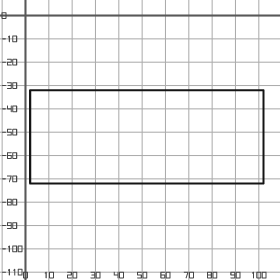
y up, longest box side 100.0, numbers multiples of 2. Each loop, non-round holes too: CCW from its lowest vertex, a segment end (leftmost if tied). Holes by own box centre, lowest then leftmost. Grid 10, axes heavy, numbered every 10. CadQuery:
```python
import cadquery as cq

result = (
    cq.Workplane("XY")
    .moveTo(2.0, -72.0)
    .lineTo(102.0, -72.0)
    .lineTo(102.0, -32.0)
    .lineTo(2.0, -32.0)
    .close()
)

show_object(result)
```